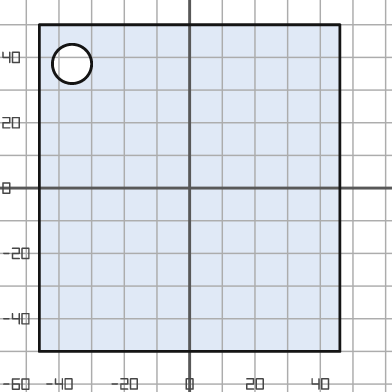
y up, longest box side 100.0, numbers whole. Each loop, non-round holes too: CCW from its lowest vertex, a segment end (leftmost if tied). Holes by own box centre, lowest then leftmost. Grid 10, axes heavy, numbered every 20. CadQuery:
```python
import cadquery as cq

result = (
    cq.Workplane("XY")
    .moveTo(-46.0, -50.0)
    .lineTo(46.0, -50.0)
    .lineTo(46.0, 50.0)
    .lineTo(-46.0, 50.0)
    .close()
    .moveTo(-36.0, 38.0)
    .circle(6.0)
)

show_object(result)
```